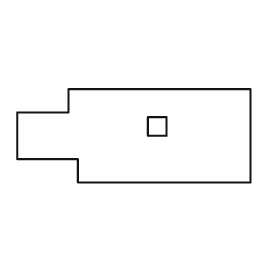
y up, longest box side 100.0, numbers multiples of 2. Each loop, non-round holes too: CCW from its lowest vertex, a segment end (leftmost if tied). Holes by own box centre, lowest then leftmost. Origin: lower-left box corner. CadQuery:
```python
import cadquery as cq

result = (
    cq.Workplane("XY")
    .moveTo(26.0, 0.0)
    .lineTo(100.0, 0.0)
    .lineTo(100.0, 40.0)
    .lineTo(22.0, 40.0)
    .lineTo(22.0, 30.0)
    .lineTo(0.0, 30.0)
    .lineTo(0.0, 10.0)
    .lineTo(26.0, 10.0)
    .close()
    .moveTo(56.0, 20.0)
    .lineTo(64.0, 20.0)
    .lineTo(64.0, 28.0)
    .lineTo(56.0, 28.0)
    .close()
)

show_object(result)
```